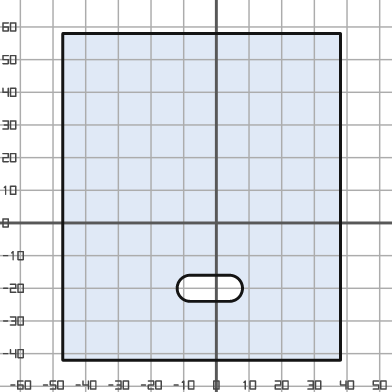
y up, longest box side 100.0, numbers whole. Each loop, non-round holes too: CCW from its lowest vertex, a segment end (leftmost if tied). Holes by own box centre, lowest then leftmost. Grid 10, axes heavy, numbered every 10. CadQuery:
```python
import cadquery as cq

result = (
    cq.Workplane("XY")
    .moveTo(-47.0, -42.0)
    .lineTo(38.0, -42.0)
    .lineTo(38.0, 58.0)
    .lineTo(-47.0, 58.0)
    .close()
    .moveTo(-8.0, -24.0)
    .lineTo(4.0, -24.0)
    .threePointArc((8.0, -20.0), (4.0, -16.0))
    .lineTo(-8.0, -16.0)
    .threePointArc((-12.0, -20.0), (-8.0, -24.0))
    .close()
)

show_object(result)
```